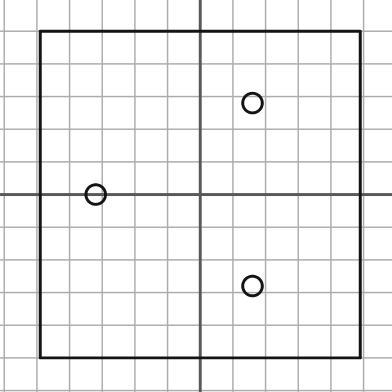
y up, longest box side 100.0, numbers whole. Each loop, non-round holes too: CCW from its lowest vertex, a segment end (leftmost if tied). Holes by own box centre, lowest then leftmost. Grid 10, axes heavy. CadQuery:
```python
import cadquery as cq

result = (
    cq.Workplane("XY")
    .moveTo(-49.0, -50.0)
    .lineTo(49.0, -50.0)
    .lineTo(49.0, 50.0)
    .lineTo(-49.0, 50.0)
    .close()
    .moveTo(16.0, -28.0)
    .circle(3.0)
    .moveTo(-32.0, 0.0)
    .circle(3.0)
    .moveTo(16.0, 28.0)
    .circle(3.0)
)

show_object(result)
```